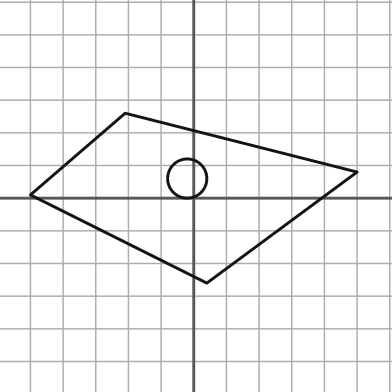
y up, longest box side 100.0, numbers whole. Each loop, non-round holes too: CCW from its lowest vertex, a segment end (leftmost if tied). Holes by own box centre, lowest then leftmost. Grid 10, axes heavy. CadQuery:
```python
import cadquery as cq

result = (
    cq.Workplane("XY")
    .moveTo(4.0, -26.0)
    .lineTo(50.0, 8.0)
    .lineTo(-21.0, 26.0)
    .lineTo(-50.0, 1.0)
    .close()
    .moveTo(-2.0, 6.0)
    .circle(6.0)
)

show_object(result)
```